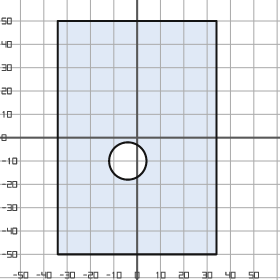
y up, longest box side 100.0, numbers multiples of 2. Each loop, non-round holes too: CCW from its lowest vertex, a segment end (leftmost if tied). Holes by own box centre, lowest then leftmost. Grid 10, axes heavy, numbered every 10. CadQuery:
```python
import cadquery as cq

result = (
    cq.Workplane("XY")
    .moveTo(-34.0, -50.0)
    .lineTo(34.0, -50.0)
    .lineTo(34.0, 50.0)
    .lineTo(-34.0, 50.0)
    .close()
    .moveTo(-4.0, -10.0)
    .circle(8.0)
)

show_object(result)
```